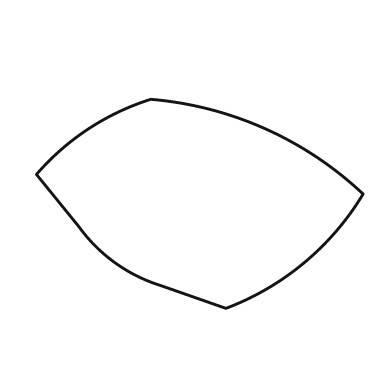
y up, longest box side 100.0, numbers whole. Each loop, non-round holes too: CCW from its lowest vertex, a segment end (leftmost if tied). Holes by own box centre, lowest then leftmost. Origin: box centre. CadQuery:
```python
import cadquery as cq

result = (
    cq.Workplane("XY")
    .moveTo(8.0, -32.0)
    .threePointArc((32.0, -18.0), (50.0, 3.0))
    .threePointArc((20.0, 23.0), (-15.0, 32.0))
    .threePointArc((-34.0, 23.0), (-50.0, 9.0))
    .lineTo(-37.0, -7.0)
    .threePointArc((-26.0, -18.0), (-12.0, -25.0))
    .close()
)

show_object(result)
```